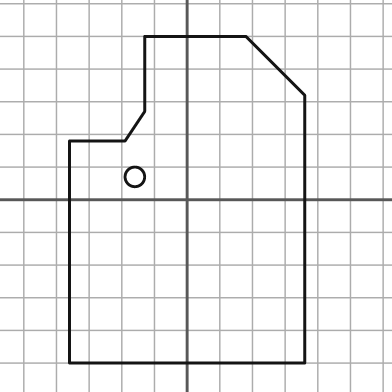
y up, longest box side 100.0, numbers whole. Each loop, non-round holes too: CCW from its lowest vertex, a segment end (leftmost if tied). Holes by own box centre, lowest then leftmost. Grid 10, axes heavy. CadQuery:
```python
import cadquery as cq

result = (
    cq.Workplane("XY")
    .moveTo(-36.0, -50.0)
    .lineTo(36.0, -50.0)
    .lineTo(36.0, 32.0)
    .lineTo(18.0, 50.0)
    .lineTo(-13.0, 50.0)
    .lineTo(-13.0, 27.0)
    .lineTo(-19.0, 18.0)
    .lineTo(-36.0, 18.0)
    .close()
    .moveTo(-16.0, 7.0)
    .circle(3.0)
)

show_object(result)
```